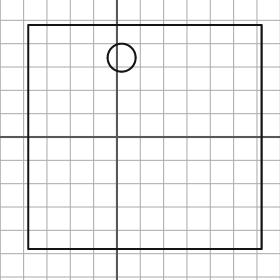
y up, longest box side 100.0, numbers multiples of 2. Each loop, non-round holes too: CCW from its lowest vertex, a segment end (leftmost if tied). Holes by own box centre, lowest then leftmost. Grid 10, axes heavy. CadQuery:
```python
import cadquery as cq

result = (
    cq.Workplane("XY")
    .moveTo(-38.0, -48.0)
    .lineTo(62.0, -48.0)
    .lineTo(62.0, 48.0)
    .lineTo(-38.0, 48.0)
    .close()
    .moveTo(2.0, 34.0)
    .circle(6.0)
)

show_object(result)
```